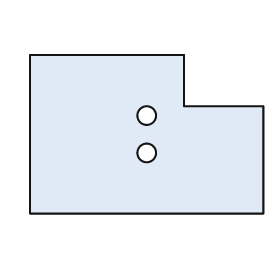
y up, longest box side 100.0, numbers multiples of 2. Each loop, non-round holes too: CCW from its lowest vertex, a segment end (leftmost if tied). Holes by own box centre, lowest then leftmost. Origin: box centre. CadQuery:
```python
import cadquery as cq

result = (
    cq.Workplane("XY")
    .moveTo(-50.0, -34.0)
    .lineTo(50.0, -34.0)
    .lineTo(50.0, 12.0)
    .lineTo(16.0, 12.0)
    .lineTo(16.0, 34.0)
    .lineTo(-50.0, 34.0)
    .close()
    .moveTo(0.0, -8.0)
    .circle(4.0)
    .moveTo(0.0, 8.0)
    .circle(4.0)
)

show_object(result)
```